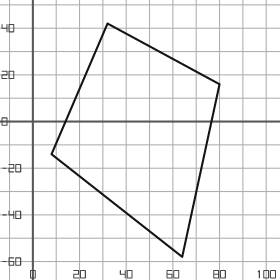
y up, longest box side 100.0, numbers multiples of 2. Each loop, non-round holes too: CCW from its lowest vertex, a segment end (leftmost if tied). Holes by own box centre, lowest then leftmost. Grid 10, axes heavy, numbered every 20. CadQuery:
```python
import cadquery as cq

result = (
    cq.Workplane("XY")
    .moveTo(64.0, -58.0)
    .lineTo(80.0, 16.0)
    .lineTo(32.0, 42.0)
    .lineTo(8.0, -14.0)
    .close()
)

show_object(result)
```